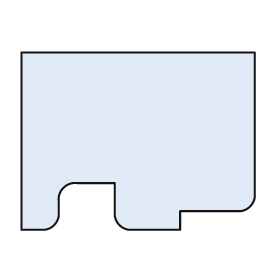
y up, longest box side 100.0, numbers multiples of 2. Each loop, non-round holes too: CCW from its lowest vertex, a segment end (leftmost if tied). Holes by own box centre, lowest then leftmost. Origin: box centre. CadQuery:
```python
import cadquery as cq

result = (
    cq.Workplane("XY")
    .moveTo(-50.0, -38.0)
    .lineTo(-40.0, -38.0)
    .threePointArc((-36.0, -36.0), (-34.0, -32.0))
    .lineTo(-34.0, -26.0)
    .threePointArc((-32.0, -20.0), (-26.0, -18.0))
    .lineTo(-10.0, -18.0)
    .lineTo(-10.0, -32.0)
    .threePointArc((-8.0, -36.0), (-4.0, -38.0))
    .lineTo(18.0, -38.0)
    .lineTo(18.0, -30.0)
    .lineTo(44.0, -30.0)
    .threePointArc((48.0, -28.0), (50.0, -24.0))
    .lineTo(50.0, 38.0)
    .lineTo(-50.0, 38.0)
    .close()
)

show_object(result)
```